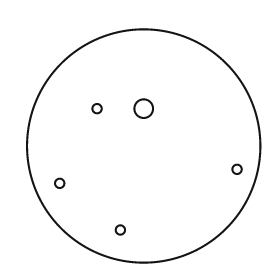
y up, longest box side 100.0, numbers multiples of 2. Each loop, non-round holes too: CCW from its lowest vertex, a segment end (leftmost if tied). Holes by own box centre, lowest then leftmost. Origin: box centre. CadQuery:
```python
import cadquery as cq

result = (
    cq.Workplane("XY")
    .moveTo(0.0, 0.0)
    .circle(50.0)
    .moveTo(-10.0, -36.0)
    .circle(2.0)
    .moveTo(-36.0, -16.0)
    .circle(2.0)
    .moveTo(40.0, -10.0)
    .circle(2.0)
    .moveTo(-20.0, 16.0)
    .circle(2.0)
    .moveTo(0.0, 16.0)
    .circle(4.0)
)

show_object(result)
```